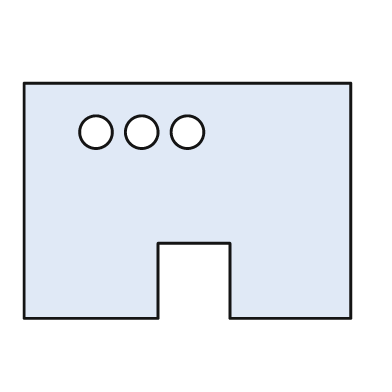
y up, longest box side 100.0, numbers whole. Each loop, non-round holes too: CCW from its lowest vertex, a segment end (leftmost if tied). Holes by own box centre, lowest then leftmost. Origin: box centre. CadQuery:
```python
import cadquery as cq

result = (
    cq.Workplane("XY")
    .moveTo(-50.0, -36.0)
    .lineTo(-9.0, -36.0)
    .lineTo(-9.0, -13.0)
    .lineTo(13.0, -13.0)
    .lineTo(13.0, -36.0)
    .lineTo(50.0, -36.0)
    .lineTo(50.0, 36.0)
    .lineTo(-50.0, 36.0)
    .close()
    .moveTo(-28.0, 21.0)
    .circle(5.0)
    .moveTo(-14.0, 21.0)
    .circle(5.0)
    .moveTo(0.0, 21.0)
    .circle(5.0)
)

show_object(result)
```